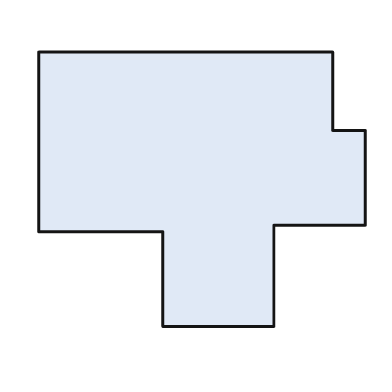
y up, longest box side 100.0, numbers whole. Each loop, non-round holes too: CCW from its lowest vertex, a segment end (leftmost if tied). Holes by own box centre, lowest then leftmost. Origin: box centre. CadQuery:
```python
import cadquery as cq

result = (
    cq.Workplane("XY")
    .moveTo(-12.0, -42.0)
    .lineTo(22.0, -42.0)
    .lineTo(22.0, -11.0)
    .lineTo(50.0, -11.0)
    .lineTo(50.0, 18.0)
    .lineTo(40.0, 18.0)
    .lineTo(40.0, 42.0)
    .lineTo(-50.0, 42.0)
    .lineTo(-50.0, -13.0)
    .lineTo(-12.0, -13.0)
    .close()
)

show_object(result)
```